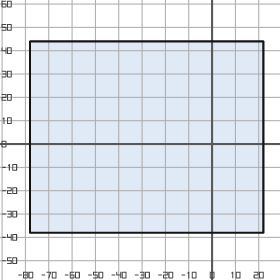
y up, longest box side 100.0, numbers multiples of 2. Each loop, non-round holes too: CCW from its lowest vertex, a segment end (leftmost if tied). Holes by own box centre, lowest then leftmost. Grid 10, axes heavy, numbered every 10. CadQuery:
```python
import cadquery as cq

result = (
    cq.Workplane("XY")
    .moveTo(-78.0, -38.0)
    .lineTo(22.0, -38.0)
    .lineTo(22.0, 44.0)
    .lineTo(-78.0, 44.0)
    .close()
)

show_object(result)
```